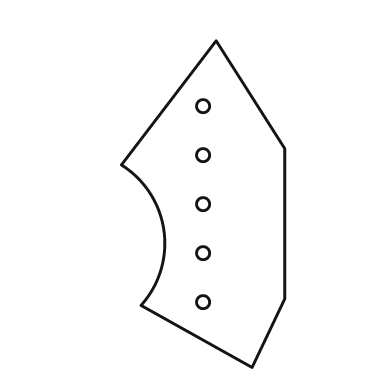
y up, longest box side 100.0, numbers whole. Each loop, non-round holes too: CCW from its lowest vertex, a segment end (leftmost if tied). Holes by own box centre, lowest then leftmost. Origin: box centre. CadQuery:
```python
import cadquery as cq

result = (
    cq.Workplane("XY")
    .moveTo(15.0, -50.0)
    .lineTo(25.0, -29.0)
    .lineTo(25.0, 17.0)
    .lineTo(4.0, 50.0)
    .lineTo(-25.0, 12.0)
    .threePointArc((-12.0, -8.0), (-19.0, -31.0))
    .close()
    .moveTo(0.0, -30.0)
    .circle(2.0)
    .moveTo(0.0, -15.0)
    .circle(2.0)
    .moveTo(0.0, 0.0)
    .circle(2.0)
    .moveTo(0.0, 15.0)
    .circle(2.0)
    .moveTo(0.0, 30.0)
    .circle(2.0)
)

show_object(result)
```